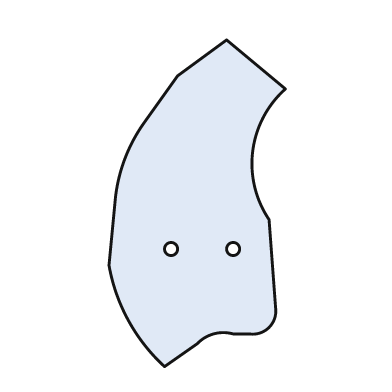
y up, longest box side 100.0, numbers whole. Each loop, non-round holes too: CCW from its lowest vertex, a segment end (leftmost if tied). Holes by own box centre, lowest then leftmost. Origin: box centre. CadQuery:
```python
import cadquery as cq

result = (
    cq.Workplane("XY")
    .moveTo(-10.0, -50.0)
    .lineTo(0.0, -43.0)
    .threePointArc((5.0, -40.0), (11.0, -40.0))
    .lineTo(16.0, -40.0)
    .threePointArc((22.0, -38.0), (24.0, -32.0))
    .lineTo(22.0, -5.0)
    .threePointArc((17.0, 16.0), (27.0, 35.0))
    .lineTo(9.0, 50.0)
    .lineTo(-6.0, 39.0)
    .lineTo(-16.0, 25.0)
    .threePointArc((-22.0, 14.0), (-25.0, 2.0))
    .lineTo(-27.0, -19.0)
    .threePointArc((-21.0, -36.0), (-10.0, -50.0))
    .close()
    .moveTo(-8.0, -14.0)
    .circle(2.0)
    .moveTo(11.0, -14.0)
    .circle(2.0)
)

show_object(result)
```